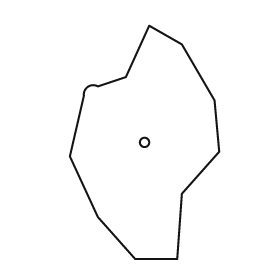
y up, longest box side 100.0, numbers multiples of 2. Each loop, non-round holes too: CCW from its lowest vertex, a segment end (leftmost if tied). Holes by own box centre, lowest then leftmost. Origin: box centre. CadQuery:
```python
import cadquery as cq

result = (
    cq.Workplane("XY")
    .moveTo(-4.0, -50.0)
    .lineTo(14.0, -50.0)
    .lineTo(16.0, -22.0)
    .lineTo(32.0, -4.0)
    .lineTo(30.0, 18.0)
    .lineTo(16.0, 42.0)
    .lineTo(2.0, 50.0)
    .lineTo(-8.0, 28.0)
    .lineTo(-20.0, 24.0)
    .threePointArc((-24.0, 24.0), (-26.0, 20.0))
    .lineTo(-32.0, -6.0)
    .lineTo(-20.0, -32.0)
    .close()
    .moveTo(0.0, 0.0)
    .circle(2.0)
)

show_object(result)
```